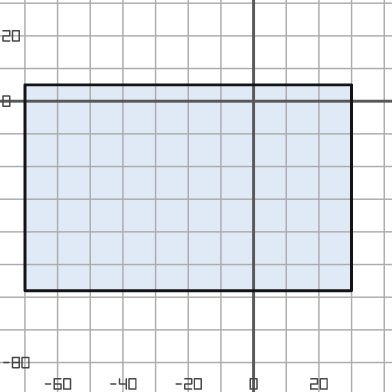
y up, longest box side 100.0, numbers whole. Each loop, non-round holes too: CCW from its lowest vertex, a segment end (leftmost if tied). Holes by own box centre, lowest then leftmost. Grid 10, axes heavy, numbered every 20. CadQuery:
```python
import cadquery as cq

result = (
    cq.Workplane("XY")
    .moveTo(-70.0, -58.0)
    .lineTo(30.0, -58.0)
    .lineTo(30.0, 5.0)
    .lineTo(-70.0, 5.0)
    .close()
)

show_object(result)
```